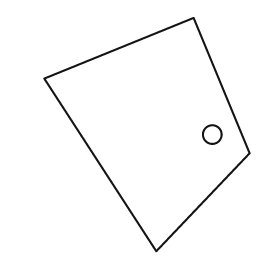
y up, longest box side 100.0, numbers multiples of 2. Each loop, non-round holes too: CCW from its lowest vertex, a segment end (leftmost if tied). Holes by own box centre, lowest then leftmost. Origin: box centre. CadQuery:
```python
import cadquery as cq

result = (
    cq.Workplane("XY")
    .moveTo(4.0, -50.0)
    .lineTo(44.0, -8.0)
    .lineTo(20.0, 50.0)
    .lineTo(-44.0, 24.0)
    .close()
    .moveTo(28.0, 0.0)
    .circle(4.0)
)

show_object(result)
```